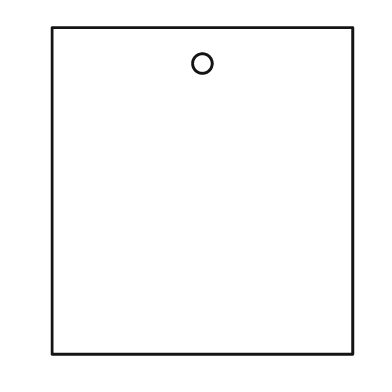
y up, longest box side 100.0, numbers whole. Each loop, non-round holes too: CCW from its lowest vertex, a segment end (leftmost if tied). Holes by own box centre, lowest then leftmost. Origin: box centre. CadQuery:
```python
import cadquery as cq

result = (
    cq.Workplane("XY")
    .moveTo(-46.0, -50.0)
    .lineTo(46.0, -50.0)
    .lineTo(46.0, 50.0)
    .lineTo(-46.0, 50.0)
    .close()
    .moveTo(0.0, 39.0)
    .circle(3.0)
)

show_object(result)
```